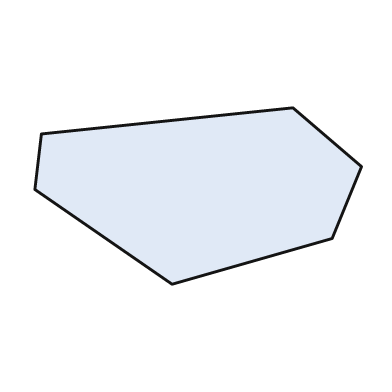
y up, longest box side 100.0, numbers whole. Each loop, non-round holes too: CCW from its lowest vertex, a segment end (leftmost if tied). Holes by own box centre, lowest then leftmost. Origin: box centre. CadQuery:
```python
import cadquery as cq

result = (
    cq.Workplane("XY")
    .moveTo(-8.0, -27.0)
    .lineTo(41.0, -13.0)
    .lineTo(50.0, 9.0)
    .lineTo(29.0, 27.0)
    .lineTo(-48.0, 19.0)
    .lineTo(-50.0, 2.0)
    .close()
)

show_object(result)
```